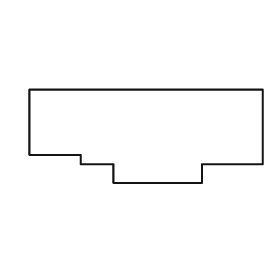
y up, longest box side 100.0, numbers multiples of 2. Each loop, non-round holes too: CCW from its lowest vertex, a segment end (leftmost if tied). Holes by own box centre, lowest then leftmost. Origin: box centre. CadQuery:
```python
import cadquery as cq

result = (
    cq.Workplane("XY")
    .moveTo(-14.0, -20.0)
    .lineTo(24.0, -20.0)
    .lineTo(24.0, -12.0)
    .lineTo(50.0, -12.0)
    .lineTo(50.0, 20.0)
    .lineTo(-50.0, 20.0)
    .lineTo(-50.0, -8.0)
    .lineTo(-28.0, -8.0)
    .lineTo(-28.0, -12.0)
    .lineTo(-14.0, -12.0)
    .close()
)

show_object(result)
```